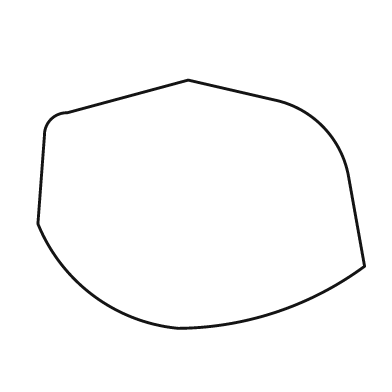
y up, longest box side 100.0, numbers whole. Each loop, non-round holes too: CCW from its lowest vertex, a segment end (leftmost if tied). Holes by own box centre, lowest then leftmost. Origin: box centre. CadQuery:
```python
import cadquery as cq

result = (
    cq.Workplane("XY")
    .moveTo(-7.0, -38.0)
    .threePointArc((23.0, -33.0), (50.0, -19.0))
    .lineTo(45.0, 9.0)
    .threePointArc((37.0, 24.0), (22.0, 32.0))
    .lineTo(-4.0, 38.0)
    .lineTo(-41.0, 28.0)
    .threePointArc((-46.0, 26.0), (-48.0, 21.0))
    .lineTo(-50.0, -6.0)
    .threePointArc((-33.0, -28.0), (-7.0, -38.0))
    .close()
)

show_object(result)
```